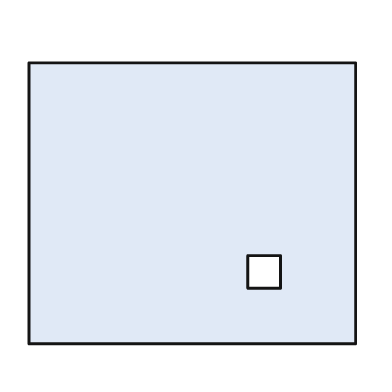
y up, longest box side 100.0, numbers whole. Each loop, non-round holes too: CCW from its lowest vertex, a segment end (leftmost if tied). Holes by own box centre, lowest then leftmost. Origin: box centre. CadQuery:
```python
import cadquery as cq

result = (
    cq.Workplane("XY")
    .moveTo(-50.0, -43.0)
    .lineTo(50.0, -43.0)
    .lineTo(50.0, 43.0)
    .lineTo(-50.0, 43.0)
    .close()
    .moveTo(17.0, -26.0)
    .lineTo(27.0, -26.0)
    .lineTo(27.0, -16.0)
    .lineTo(17.0, -16.0)
    .close()
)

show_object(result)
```